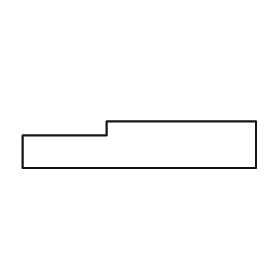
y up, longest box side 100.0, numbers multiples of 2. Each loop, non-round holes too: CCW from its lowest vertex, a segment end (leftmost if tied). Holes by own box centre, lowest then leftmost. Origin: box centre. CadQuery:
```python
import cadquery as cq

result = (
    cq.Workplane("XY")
    .moveTo(-50.0, -10.0)
    .lineTo(50.0, -10.0)
    .lineTo(50.0, 10.0)
    .lineTo(-14.0, 10.0)
    .lineTo(-14.0, 4.0)
    .lineTo(-50.0, 4.0)
    .close()
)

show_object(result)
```